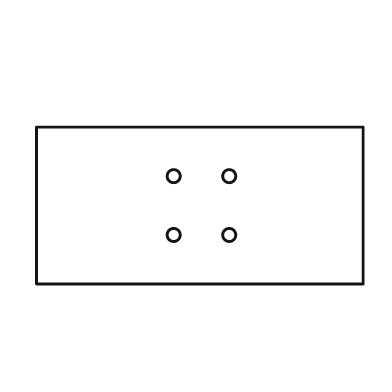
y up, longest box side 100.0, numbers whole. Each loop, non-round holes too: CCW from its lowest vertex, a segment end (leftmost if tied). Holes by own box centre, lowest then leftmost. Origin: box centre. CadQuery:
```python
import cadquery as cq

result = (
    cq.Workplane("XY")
    .moveTo(-50.0, -24.0)
    .lineTo(50.0, -24.0)
    .lineTo(50.0, 24.0)
    .lineTo(-50.0, 24.0)
    .close()
    .moveTo(-8.0, -9.0)
    .circle(2.0)
    .moveTo(9.0, -9.0)
    .circle(2.0)
    .moveTo(-8.0, 9.0)
    .circle(2.0)
    .moveTo(9.0, 9.0)
    .circle(2.0)
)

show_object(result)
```